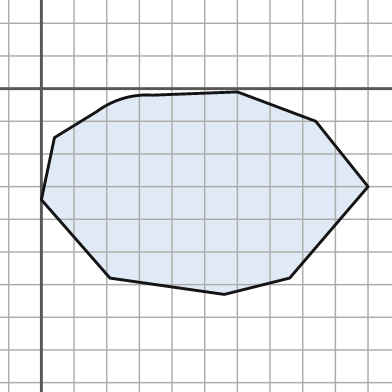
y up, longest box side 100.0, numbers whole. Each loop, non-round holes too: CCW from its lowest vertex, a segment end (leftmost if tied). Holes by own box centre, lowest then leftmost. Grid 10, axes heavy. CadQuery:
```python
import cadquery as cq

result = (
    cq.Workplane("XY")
    .moveTo(56.0, -63.0)
    .lineTo(76.0, -58.0)
    .lineTo(100.0, -30.0)
    .lineTo(84.0, -10.0)
    .lineTo(60.0, -1.0)
    .lineTo(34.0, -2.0)
    .threePointArc((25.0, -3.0), (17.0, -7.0))
    .lineTo(4.0, -15.0)
    .lineTo(0.0, -34.0)
    .lineTo(21.0, -58.0)
    .close()
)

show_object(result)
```